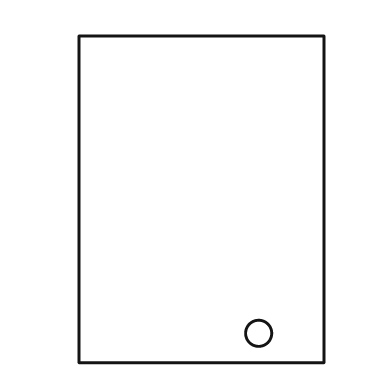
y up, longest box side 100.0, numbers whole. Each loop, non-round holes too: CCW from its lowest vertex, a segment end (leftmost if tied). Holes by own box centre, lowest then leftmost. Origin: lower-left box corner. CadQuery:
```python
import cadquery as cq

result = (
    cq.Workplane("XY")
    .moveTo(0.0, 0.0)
    .lineTo(75.0, 0.0)
    .lineTo(75.0, 100.0)
    .lineTo(0.0, 100.0)
    .close()
    .moveTo(55.0, 9.0)
    .circle(4.0)
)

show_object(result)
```